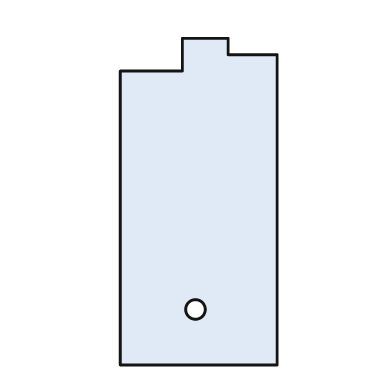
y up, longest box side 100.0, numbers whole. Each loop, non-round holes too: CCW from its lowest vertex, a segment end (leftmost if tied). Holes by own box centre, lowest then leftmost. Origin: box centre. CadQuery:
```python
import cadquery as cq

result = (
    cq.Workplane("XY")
    .moveTo(-24.0, -50.0)
    .lineTo(24.0, -50.0)
    .lineTo(24.0, 45.0)
    .lineTo(9.0, 45.0)
    .lineTo(9.0, 50.0)
    .lineTo(-5.0, 50.0)
    .lineTo(-5.0, 40.0)
    .lineTo(-24.0, 40.0)
    .close()
    .moveTo(-1.0, -33.0)
    .circle(3.0)
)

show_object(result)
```